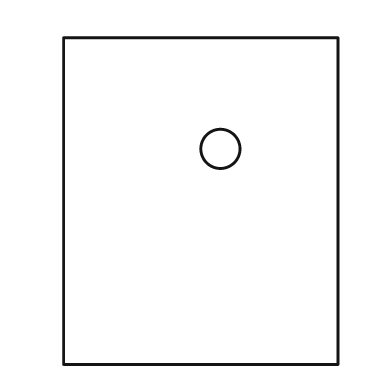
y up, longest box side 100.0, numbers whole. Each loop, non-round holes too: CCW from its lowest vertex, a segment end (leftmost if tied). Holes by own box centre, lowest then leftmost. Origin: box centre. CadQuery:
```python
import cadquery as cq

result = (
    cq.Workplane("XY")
    .moveTo(-42.0, -50.0)
    .lineTo(42.0, -50.0)
    .lineTo(42.0, 50.0)
    .lineTo(-42.0, 50.0)
    .close()
    .moveTo(6.0, 16.0)
    .circle(6.0)
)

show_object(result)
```